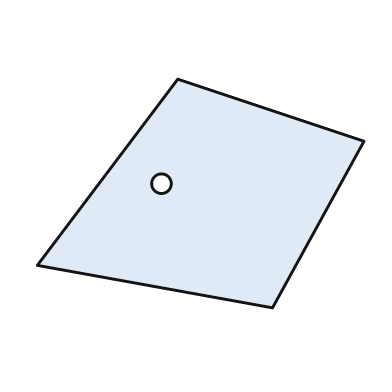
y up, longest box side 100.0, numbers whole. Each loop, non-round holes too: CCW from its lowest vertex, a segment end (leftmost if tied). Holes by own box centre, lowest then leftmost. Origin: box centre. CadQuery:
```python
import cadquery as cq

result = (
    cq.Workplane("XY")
    .moveTo(22.0, -35.0)
    .lineTo(50.0, 16.0)
    .lineTo(-7.0, 35.0)
    .lineTo(-50.0, -22.0)
    .close()
    .moveTo(-12.0, 3.0)
    .circle(3.0)
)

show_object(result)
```